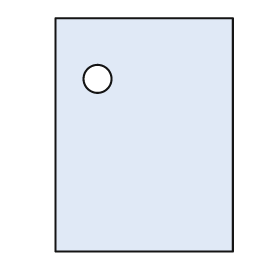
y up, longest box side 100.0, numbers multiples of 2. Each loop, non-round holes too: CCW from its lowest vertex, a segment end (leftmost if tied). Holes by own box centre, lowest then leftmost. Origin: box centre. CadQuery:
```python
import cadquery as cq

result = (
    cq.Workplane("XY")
    .moveTo(-38.0, -50.0)
    .lineTo(38.0, -50.0)
    .lineTo(38.0, 50.0)
    .lineTo(-38.0, 50.0)
    .close()
    .moveTo(-20.0, 24.0)
    .circle(6.0)
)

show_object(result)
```